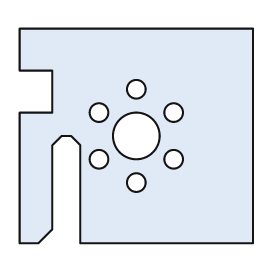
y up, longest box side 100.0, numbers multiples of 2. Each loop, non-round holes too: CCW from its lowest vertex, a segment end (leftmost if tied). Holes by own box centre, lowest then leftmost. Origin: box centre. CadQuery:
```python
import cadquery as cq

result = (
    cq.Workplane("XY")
    .moveTo(-50.0, -46.0)
    .lineTo(-42.0, -46.0)
    .lineTo(-36.0, -40.0)
    .lineTo(-36.0, -4.0)
    .lineTo(-32.0, 0.0)
    .lineTo(-28.0, 0.0)
    .lineTo(-24.0, -4.0)
    .lineTo(-24.0, -46.0)
    .lineTo(50.0, -46.0)
    .lineTo(50.0, 46.0)
    .lineTo(-50.0, 46.0)
    .lineTo(-50.0, 28.0)
    .lineTo(-36.0, 28.0)
    .lineTo(-36.0, 10.0)
    .lineTo(-50.0, 10.0)
    .close()
    .moveTo(0.0, -20.0)
    .circle(4.0)
    .moveTo(-16.0, -10.0)
    .circle(4.0)
    .moveTo(16.0, -10.0)
    .circle(4.0)
    .moveTo(0.0, 0.0)
    .circle(10.0)
    .moveTo(-16.0, 10.0)
    .circle(4.0)
    .moveTo(16.0, 10.0)
    .circle(4.0)
    .moveTo(0.0, 20.0)
    .circle(4.0)
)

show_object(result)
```